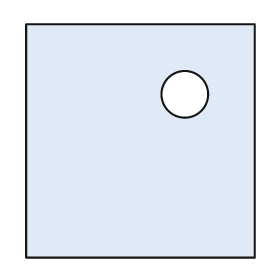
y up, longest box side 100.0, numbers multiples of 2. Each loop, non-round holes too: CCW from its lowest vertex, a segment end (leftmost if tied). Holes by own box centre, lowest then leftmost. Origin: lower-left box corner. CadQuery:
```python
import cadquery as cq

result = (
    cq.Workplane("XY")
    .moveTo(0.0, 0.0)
    .lineTo(98.0, 0.0)
    .lineTo(98.0, 100.0)
    .lineTo(0.0, 100.0)
    .close()
    .moveTo(68.0, 70.0)
    .circle(10.0)
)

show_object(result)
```